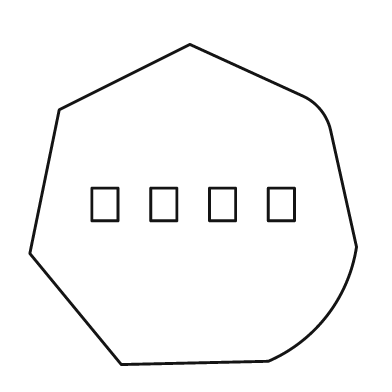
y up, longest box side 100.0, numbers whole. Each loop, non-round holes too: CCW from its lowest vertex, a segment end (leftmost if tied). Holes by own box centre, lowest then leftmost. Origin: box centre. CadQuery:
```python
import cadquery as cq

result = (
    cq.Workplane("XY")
    .moveTo(-22.0, -49.0)
    .lineTo(23.0, -48.0)
    .threePointArc((41.0, -34.0), (50.0, -13.0))
    .lineTo(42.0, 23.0)
    .threePointArc((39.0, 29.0), (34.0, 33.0))
    .lineTo(-1.0, 49.0)
    .lineTo(-41.0, 29.0)
    .lineTo(-50.0, -15.0)
    .close()
    .moveTo(-31.0, -5.0)
    .lineTo(-23.0, -5.0)
    .lineTo(-23.0, 5.0)
    .lineTo(-31.0, 5.0)
    .close()
    .moveTo(-13.0, -5.0)
    .lineTo(-5.0, -5.0)
    .lineTo(-5.0, 5.0)
    .lineTo(-13.0, 5.0)
    .close()
    .moveTo(5.0, -5.0)
    .lineTo(13.0, -5.0)
    .lineTo(13.0, 5.0)
    .lineTo(5.0, 5.0)
    .close()
    .moveTo(23.0, -5.0)
    .lineTo(31.0, -5.0)
    .lineTo(31.0, 5.0)
    .lineTo(23.0, 5.0)
    .close()
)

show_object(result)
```